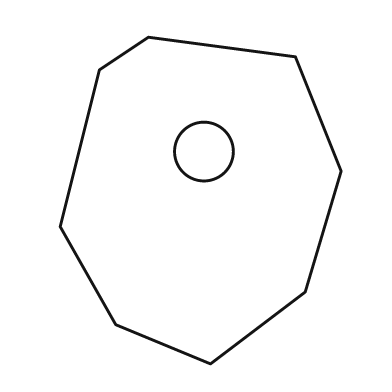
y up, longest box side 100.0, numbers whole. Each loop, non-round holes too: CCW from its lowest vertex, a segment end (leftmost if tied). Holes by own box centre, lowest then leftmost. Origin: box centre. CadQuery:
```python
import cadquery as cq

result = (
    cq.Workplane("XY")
    .moveTo(3.0, -50.0)
    .lineTo(32.0, -28.0)
    .lineTo(43.0, 9.0)
    .lineTo(29.0, 44.0)
    .lineTo(-16.0, 50.0)
    .lineTo(-31.0, 40.0)
    .lineTo(-43.0, -8.0)
    .lineTo(-26.0, -38.0)
    .close()
    .moveTo(1.0, 15.0)
    .circle(9.0)
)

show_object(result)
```